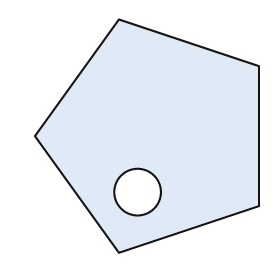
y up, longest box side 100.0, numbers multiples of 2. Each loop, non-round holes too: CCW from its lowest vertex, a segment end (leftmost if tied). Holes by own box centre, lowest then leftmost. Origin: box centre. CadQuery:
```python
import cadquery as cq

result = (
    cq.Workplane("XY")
    .moveTo(-12.0, -50.0)
    .lineTo(48.0, -30.0)
    .lineTo(48.0, 30.0)
    .lineTo(-12.0, 50.0)
    .lineTo(-48.0, 0.0)
    .close()
    .moveTo(-4.0, -24.0)
    .circle(10.0)
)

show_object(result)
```